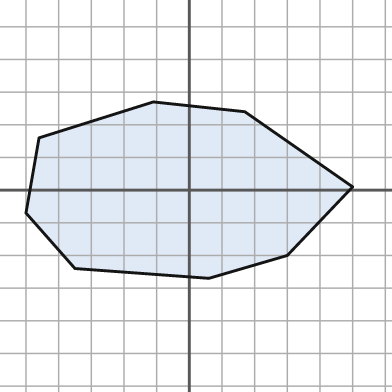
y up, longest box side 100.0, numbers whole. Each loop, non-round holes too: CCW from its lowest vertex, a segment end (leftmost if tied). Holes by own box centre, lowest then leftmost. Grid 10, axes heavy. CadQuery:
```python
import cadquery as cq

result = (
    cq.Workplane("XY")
    .moveTo(6.0, -27.0)
    .lineTo(30.0, -20.0)
    .lineTo(50.0, 1.0)
    .lineTo(17.0, 24.0)
    .lineTo(-11.0, 27.0)
    .lineTo(-46.0, 16.0)
    .lineTo(-50.0, -7.0)
    .lineTo(-35.0, -24.0)
    .close()
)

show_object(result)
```